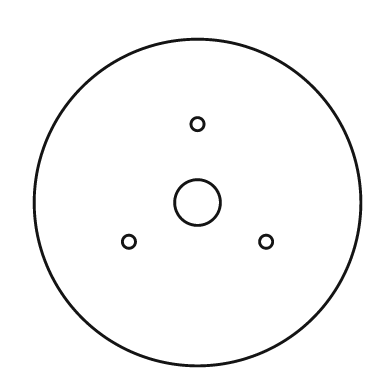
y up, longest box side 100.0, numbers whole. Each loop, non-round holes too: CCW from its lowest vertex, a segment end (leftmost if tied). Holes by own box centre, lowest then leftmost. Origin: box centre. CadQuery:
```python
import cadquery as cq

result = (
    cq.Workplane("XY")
    .moveTo(0.0, 0.0)
    .circle(50.0)
    .moveTo(-21.0, -12.0)
    .circle(2.0)
    .moveTo(21.0, -12.0)
    .circle(2.0)
    .moveTo(0.0, 0.0)
    .circle(7.0)
    .moveTo(0.0, 24.0)
    .circle(2.0)
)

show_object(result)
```